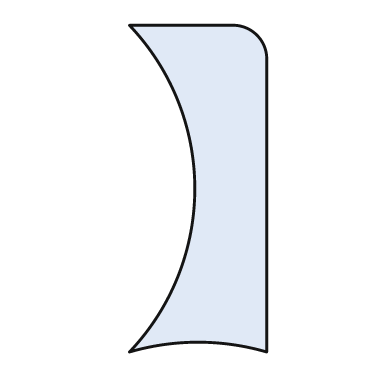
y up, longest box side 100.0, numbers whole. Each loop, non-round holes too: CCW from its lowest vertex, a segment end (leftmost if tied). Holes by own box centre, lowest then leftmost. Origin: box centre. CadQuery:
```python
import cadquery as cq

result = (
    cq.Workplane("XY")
    .moveTo(-21.0, -50.0)
    .threePointArc((0.0, -47.0), (21.0, -50.0))
    .lineTo(21.0, 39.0)
    .threePointArc((18.0, 47.0), (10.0, 50.0))
    .lineTo(-21.0, 50.0)
    .threePointArc((-1.0, 0.0), (-21.0, -50.0))
    .close()
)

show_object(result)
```